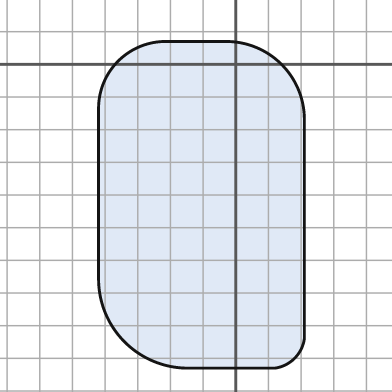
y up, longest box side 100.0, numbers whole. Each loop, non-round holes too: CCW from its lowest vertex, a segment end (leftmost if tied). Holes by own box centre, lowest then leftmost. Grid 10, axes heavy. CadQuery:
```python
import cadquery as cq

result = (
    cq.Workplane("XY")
    .moveTo(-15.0, -93.0)
    .lineTo(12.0, -93.0)
    .threePointArc((18.0, -90.0), (21.0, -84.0))
    .lineTo(21.0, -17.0)
    .threePointArc((14.0, 0.0), (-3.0, 7.0))
    .lineTo(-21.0, 7.0)
    .threePointArc((-36.0, 1.0), (-42.0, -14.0))
    .lineTo(-42.0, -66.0)
    .threePointArc((-34.0, -85.0), (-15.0, -93.0))
    .close()
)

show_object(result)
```